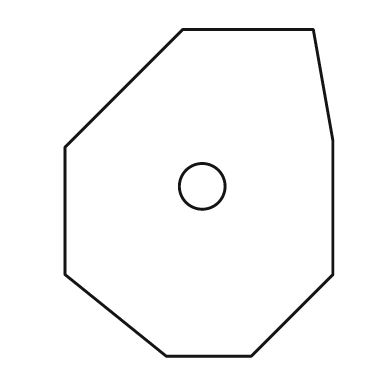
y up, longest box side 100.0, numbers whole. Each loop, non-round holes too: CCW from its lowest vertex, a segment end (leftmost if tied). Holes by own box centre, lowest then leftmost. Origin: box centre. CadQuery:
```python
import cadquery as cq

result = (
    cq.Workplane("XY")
    .moveTo(-10.0, -50.0)
    .lineTo(16.0, -50.0)
    .lineTo(41.0, -25.0)
    .lineTo(41.0, 16.0)
    .lineTo(35.0, 50.0)
    .lineTo(-5.0, 50.0)
    .lineTo(-41.0, 14.0)
    .lineTo(-41.0, -25.0)
    .close()
    .moveTo(1.0, 2.0)
    .circle(7.0)
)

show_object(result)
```